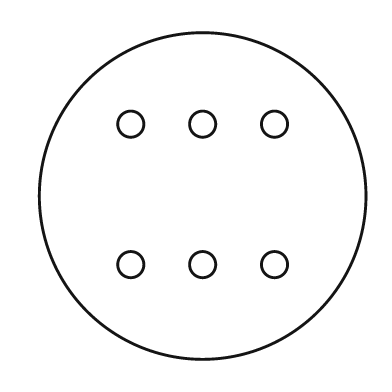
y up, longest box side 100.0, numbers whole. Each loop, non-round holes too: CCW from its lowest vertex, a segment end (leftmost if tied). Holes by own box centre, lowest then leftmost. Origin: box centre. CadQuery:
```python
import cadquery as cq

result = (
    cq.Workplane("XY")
    .moveTo(0.0, 0.0)
    .circle(50.0)
    .moveTo(-22.0, -21.0)
    .circle(4.0)
    .moveTo(0.0, -21.0)
    .circle(4.0)
    .moveTo(22.0, -21.0)
    .circle(4.0)
    .moveTo(-22.0, 22.0)
    .circle(4.0)
    .moveTo(0.0, 22.0)
    .circle(4.0)
    .moveTo(22.0, 22.0)
    .circle(4.0)
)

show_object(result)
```